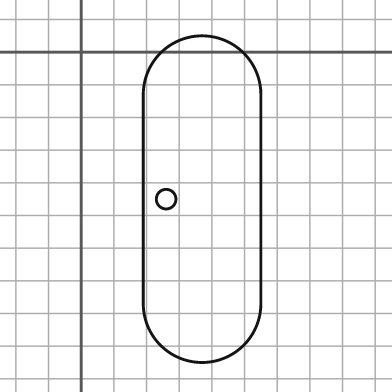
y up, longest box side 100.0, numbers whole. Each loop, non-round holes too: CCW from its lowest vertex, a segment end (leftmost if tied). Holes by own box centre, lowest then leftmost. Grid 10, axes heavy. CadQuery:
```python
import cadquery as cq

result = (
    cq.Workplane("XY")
    .moveTo(19.0, -77.0)
    .threePointArc((37.0, -95.0), (55.0, -77.0))
    .lineTo(55.0, -13.0)
    .threePointArc((37.0, 5.0), (19.0, -13.0))
    .close()
    .moveTo(26.0, -45.0)
    .circle(3.0)
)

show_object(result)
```